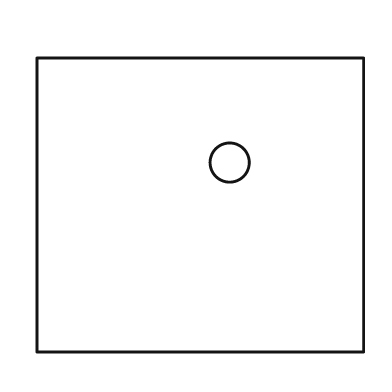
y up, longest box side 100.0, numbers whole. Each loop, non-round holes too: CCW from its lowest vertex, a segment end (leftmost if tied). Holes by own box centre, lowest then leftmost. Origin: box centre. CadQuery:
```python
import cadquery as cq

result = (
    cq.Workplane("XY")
    .moveTo(-50.0, -45.0)
    .lineTo(50.0, -45.0)
    .lineTo(50.0, 45.0)
    .lineTo(-50.0, 45.0)
    .close()
    .moveTo(9.0, 13.0)
    .circle(6.0)
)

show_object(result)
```